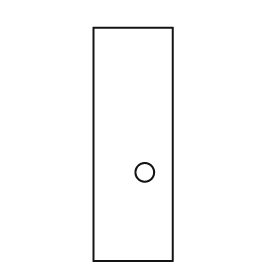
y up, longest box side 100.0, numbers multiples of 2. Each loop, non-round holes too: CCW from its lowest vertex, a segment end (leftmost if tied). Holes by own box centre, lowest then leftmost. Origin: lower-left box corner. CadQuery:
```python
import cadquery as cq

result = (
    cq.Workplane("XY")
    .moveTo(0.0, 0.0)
    .lineTo(34.0, 0.0)
    .lineTo(34.0, 100.0)
    .lineTo(0.0, 100.0)
    .close()
    .moveTo(22.0, 38.0)
    .circle(4.0)
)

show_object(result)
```